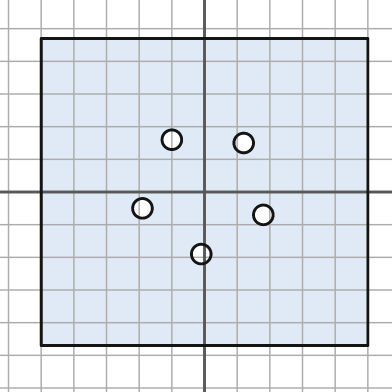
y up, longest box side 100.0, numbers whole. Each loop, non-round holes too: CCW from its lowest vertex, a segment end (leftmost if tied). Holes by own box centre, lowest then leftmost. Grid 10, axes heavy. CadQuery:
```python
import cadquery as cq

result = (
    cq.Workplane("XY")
    .moveTo(-50.0, -47.0)
    .lineTo(50.0, -47.0)
    .lineTo(50.0, 47.0)
    .lineTo(-50.0, 47.0)
    .close()
    .moveTo(-1.0, -19.0)
    .circle(3.0)
    .moveTo(18.0, -7.0)
    .circle(3.0)
    .moveTo(-19.0, -5.0)
    .circle(3.0)
    .moveTo(12.0, 15.0)
    .circle(3.0)
    .moveTo(-10.0, 16.0)
    .circle(3.0)
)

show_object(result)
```